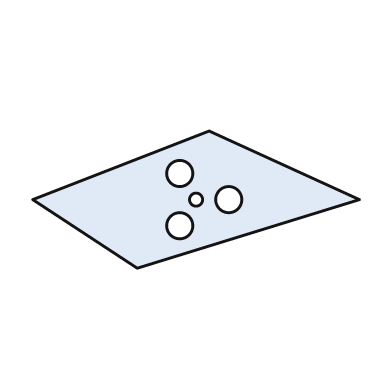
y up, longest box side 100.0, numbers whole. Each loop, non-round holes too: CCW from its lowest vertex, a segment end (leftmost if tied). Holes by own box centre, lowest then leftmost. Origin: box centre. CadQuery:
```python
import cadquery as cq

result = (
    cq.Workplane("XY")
    .moveTo(-18.0, -21.0)
    .lineTo(50.0, 0.0)
    .lineTo(4.0, 21.0)
    .lineTo(-50.0, 0.0)
    .close()
    .moveTo(-5.0, -8.0)
    .circle(4.0)
    .moveTo(0.0, 0.0)
    .circle(2.0)
    .moveTo(10.0, 0.0)
    .circle(4.0)
    .moveTo(-5.0, 8.0)
    .circle(4.0)
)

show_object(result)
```